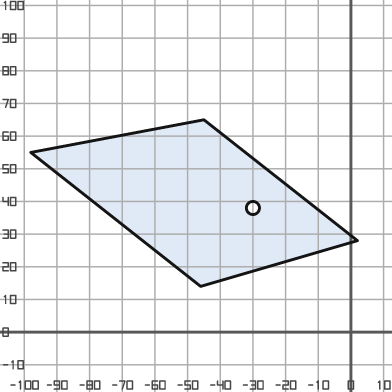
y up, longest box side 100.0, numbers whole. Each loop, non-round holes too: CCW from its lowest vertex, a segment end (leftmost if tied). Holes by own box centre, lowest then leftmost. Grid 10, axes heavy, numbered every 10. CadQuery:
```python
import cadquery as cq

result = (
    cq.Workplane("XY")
    .moveTo(-46.0, 14.0)
    .lineTo(2.0, 28.0)
    .lineTo(-45.0, 65.0)
    .lineTo(-98.0, 55.0)
    .close()
    .moveTo(-30.0, 38.0)
    .circle(2.0)
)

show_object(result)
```